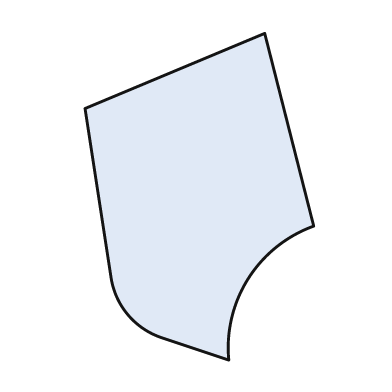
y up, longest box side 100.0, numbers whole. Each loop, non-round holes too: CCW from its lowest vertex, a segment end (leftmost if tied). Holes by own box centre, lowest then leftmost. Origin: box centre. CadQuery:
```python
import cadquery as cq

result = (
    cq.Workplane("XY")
    .moveTo(9.0, -50.0)
    .threePointArc((15.0, -25.0), (35.0, -9.0))
    .lineTo(20.0, 50.0)
    .lineTo(-35.0, 27.0)
    .lineTo(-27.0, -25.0)
    .threePointArc((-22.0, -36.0), (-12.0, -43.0))
    .close()
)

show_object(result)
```